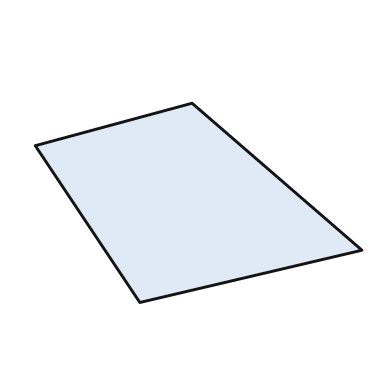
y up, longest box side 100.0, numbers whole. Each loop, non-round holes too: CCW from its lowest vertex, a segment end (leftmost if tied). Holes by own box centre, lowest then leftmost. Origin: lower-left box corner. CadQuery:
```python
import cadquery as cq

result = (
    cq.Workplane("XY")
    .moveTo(32.0, 0.0)
    .lineTo(100.0, 16.0)
    .lineTo(48.0, 61.0)
    .lineTo(0.0, 48.0)
    .close()
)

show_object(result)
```